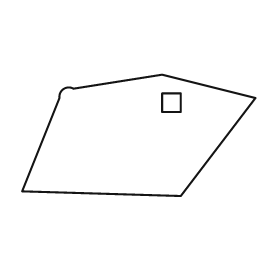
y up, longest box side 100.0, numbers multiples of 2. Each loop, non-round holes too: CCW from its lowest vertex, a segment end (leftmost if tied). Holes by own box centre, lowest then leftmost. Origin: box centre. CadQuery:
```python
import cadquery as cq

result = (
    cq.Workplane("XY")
    .moveTo(18.0, -26.0)
    .lineTo(50.0, 16.0)
    .lineTo(10.0, 26.0)
    .lineTo(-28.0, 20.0)
    .threePointArc((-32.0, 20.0), (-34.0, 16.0))
    .lineTo(-50.0, -24.0)
    .close()
    .moveTo(10.0, 10.0)
    .lineTo(18.0, 10.0)
    .lineTo(18.0, 18.0)
    .lineTo(10.0, 18.0)
    .close()
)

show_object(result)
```